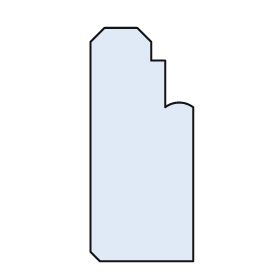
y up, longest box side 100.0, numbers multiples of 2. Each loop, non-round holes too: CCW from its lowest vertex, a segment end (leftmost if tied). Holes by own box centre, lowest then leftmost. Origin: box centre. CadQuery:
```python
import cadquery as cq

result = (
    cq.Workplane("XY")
    .moveTo(-18.0, -50.0)
    .lineTo(22.0, -50.0)
    .lineTo(22.0, 16.0)
    .threePointArc((16.0, 18.0), (10.0, 16.0))
    .lineTo(10.0, 36.0)
    .lineTo(4.0, 36.0)
    .lineTo(4.0, 44.0)
    .lineTo(-2.0, 50.0)
    .lineTo(-16.0, 50.0)
    .lineTo(-22.0, 44.0)
    .lineTo(-22.0, -46.0)
    .close()
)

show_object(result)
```